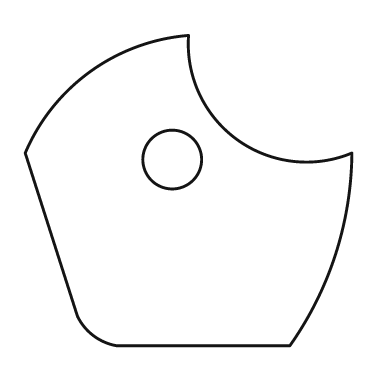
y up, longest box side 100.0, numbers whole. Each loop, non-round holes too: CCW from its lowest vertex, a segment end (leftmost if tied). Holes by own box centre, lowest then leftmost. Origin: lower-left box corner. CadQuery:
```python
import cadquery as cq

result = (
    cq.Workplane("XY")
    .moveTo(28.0, 0.0)
    .lineTo(81.0, 0.0)
    .threePointArc((95.0, 28.0), (100.0, 59.0))
    .threePointArc((65.0, 63.0), (50.0, 95.0))
    .threePointArc((20.0, 84.0), (0.0, 59.0))
    .lineTo(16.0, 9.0)
    .threePointArc((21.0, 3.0), (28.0, 0.0))
    .close()
    .moveTo(45.0, 57.0)
    .circle(9.0)
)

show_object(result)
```